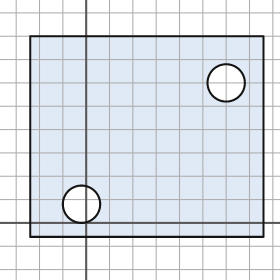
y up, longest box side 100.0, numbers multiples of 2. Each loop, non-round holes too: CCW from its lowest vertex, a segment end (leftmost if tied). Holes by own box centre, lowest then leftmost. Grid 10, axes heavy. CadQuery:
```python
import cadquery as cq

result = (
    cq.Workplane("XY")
    .moveTo(-24.0, -6.0)
    .lineTo(76.0, -6.0)
    .lineTo(76.0, 80.0)
    .lineTo(-24.0, 80.0)
    .close()
    .moveTo(-2.0, 8.0)
    .circle(8.0)
    .moveTo(60.0, 60.0)
    .circle(8.0)
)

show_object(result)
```